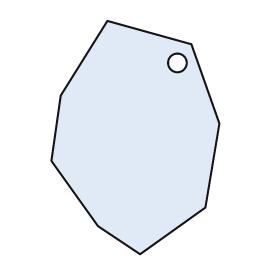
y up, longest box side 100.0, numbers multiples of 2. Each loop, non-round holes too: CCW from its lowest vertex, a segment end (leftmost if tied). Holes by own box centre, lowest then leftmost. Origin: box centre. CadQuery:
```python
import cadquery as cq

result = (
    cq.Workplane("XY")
    .moveTo(2.0, -50.0)
    .lineTo(30.0, -30.0)
    .lineTo(36.0, 6.0)
    .lineTo(24.0, 40.0)
    .lineTo(-12.0, 50.0)
    .lineTo(-32.0, 18.0)
    .lineTo(-36.0, -10.0)
    .lineTo(-16.0, -38.0)
    .close()
    .moveTo(18.0, 32.0)
    .circle(4.0)
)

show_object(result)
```